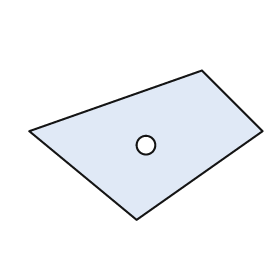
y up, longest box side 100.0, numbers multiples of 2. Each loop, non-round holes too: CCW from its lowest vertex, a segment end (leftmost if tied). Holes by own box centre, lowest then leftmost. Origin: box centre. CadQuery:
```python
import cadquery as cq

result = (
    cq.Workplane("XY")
    .moveTo(-4.0, -32.0)
    .lineTo(50.0, 6.0)
    .lineTo(24.0, 32.0)
    .lineTo(-50.0, 6.0)
    .close()
    .moveTo(0.0, 0.0)
    .circle(4.0)
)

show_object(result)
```